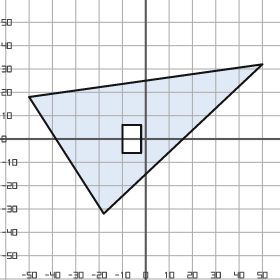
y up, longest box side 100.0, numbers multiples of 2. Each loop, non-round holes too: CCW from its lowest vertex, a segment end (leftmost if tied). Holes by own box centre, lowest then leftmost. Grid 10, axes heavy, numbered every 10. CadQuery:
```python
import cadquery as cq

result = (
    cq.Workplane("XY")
    .moveTo(-18.0, -32.0)
    .lineTo(50.0, 32.0)
    .lineTo(-50.0, 18.0)
    .close()
    .moveTo(-10.0, -6.0)
    .lineTo(-2.0, -6.0)
    .lineTo(-2.0, 6.0)
    .lineTo(-10.0, 6.0)
    .close()
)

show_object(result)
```